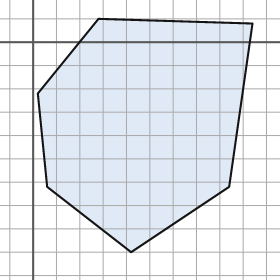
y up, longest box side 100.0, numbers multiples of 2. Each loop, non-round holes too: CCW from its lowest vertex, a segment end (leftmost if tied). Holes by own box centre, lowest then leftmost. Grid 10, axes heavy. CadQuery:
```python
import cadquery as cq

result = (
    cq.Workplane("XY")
    .moveTo(42.0, -90.0)
    .lineTo(84.0, -62.0)
    .lineTo(94.0, 8.0)
    .lineTo(28.0, 10.0)
    .lineTo(2.0, -22.0)
    .lineTo(6.0, -62.0)
    .close()
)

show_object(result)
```